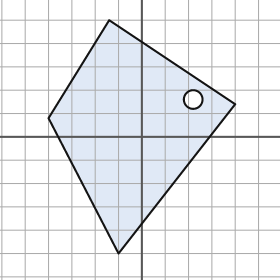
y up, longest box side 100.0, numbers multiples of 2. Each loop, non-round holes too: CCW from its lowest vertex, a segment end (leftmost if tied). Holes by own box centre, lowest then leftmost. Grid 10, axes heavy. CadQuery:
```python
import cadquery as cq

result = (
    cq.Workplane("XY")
    .moveTo(-10.0, -50.0)
    .lineTo(40.0, 14.0)
    .lineTo(-14.0, 50.0)
    .lineTo(-40.0, 8.0)
    .close()
    .moveTo(22.0, 16.0)
    .circle(4.0)
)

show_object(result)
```